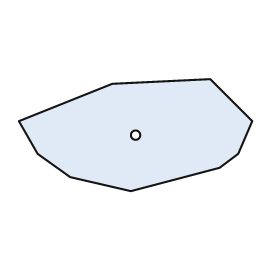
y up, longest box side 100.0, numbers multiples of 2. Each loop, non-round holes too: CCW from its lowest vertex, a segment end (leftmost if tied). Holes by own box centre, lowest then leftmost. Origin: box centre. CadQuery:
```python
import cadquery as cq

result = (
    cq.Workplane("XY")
    .moveTo(-2.0, -24.0)
    .lineTo(36.0, -14.0)
    .lineTo(44.0, -8.0)
    .lineTo(50.0, 6.0)
    .lineTo(32.0, 24.0)
    .lineTo(-10.0, 22.0)
    .lineTo(-50.0, 6.0)
    .lineTo(-42.0, -8.0)
    .lineTo(-28.0, -18.0)
    .close()
    .moveTo(0.0, 0.0)
    .circle(2.0)
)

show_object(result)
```